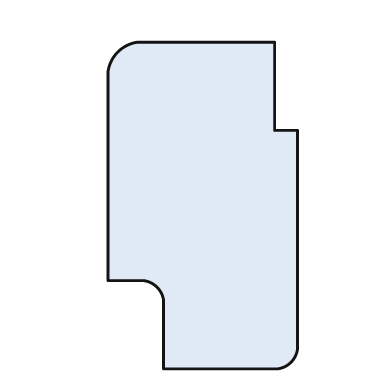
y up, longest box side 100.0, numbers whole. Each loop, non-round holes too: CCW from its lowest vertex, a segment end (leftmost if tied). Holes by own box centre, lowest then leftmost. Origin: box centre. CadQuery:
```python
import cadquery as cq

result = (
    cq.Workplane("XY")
    .moveTo(-12.0, -50.0)
    .lineTo(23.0, -50.0)
    .threePointArc((27.0, -48.0), (29.0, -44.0))
    .lineTo(29.0, 23.0)
    .lineTo(22.0, 23.0)
    .lineTo(22.0, 50.0)
    .lineTo(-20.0, 50.0)
    .threePointArc((-26.0, 47.0), (-29.0, 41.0))
    .lineTo(-29.0, -23.0)
    .lineTo(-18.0, -23.0)
    .threePointArc((-14.0, -25.0), (-12.0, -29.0))
    .close()
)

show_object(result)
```